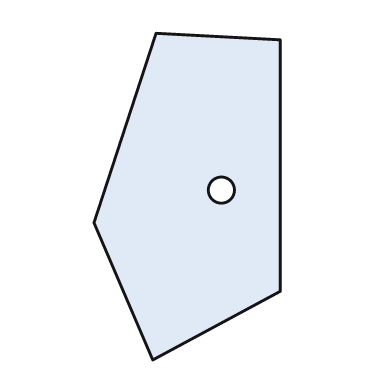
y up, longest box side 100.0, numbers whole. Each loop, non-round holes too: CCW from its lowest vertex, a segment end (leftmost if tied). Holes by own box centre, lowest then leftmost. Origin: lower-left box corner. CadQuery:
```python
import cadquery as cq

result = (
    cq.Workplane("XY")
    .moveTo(18.0, 0.0)
    .lineTo(57.0, 21.0)
    .lineTo(57.0, 98.0)
    .lineTo(19.0, 100.0)
    .lineTo(0.0, 42.0)
    .close()
    .moveTo(39.0, 52.0)
    .circle(4.0)
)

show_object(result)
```